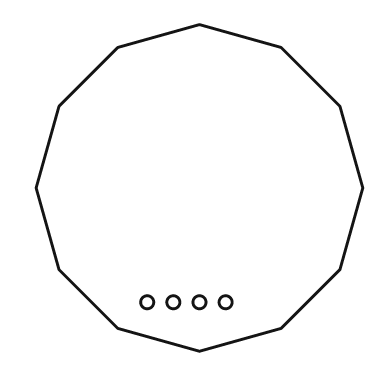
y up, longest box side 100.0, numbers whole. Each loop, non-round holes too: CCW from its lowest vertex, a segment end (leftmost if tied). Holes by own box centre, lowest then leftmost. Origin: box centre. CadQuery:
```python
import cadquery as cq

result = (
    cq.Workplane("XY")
    .moveTo(0.0, -50.0)
    .lineTo(25.0, -43.0)
    .lineTo(43.0, -25.0)
    .lineTo(50.0, 0.0)
    .lineTo(43.0, 25.0)
    .lineTo(25.0, 43.0)
    .lineTo(0.0, 50.0)
    .lineTo(-25.0, 43.0)
    .lineTo(-43.0, 25.0)
    .lineTo(-50.0, 0.0)
    .lineTo(-43.0, -25.0)
    .lineTo(-25.0, -43.0)
    .close()
    .moveTo(-16.0, -35.0)
    .circle(2.0)
    .moveTo(-8.0, -35.0)
    .circle(2.0)
    .moveTo(0.0, -35.0)
    .circle(2.0)
    .moveTo(8.0, -35.0)
    .circle(2.0)
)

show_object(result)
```